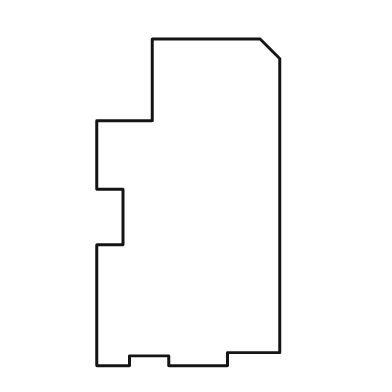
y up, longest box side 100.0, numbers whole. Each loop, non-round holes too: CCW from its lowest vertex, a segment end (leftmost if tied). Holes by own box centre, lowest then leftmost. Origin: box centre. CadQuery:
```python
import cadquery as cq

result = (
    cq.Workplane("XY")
    .moveTo(-28.0, -50.0)
    .lineTo(-18.0, -50.0)
    .lineTo(-18.0, -47.0)
    .lineTo(-6.0, -47.0)
    .lineTo(-6.0, -50.0)
    .lineTo(12.0, -50.0)
    .lineTo(12.0, -46.0)
    .lineTo(28.0, -46.0)
    .lineTo(28.0, 44.0)
    .lineTo(22.0, 50.0)
    .lineTo(-11.0, 50.0)
    .lineTo(-11.0, 25.0)
    .lineTo(-28.0, 25.0)
    .lineTo(-28.0, 4.0)
    .lineTo(-20.0, 4.0)
    .lineTo(-20.0, -13.0)
    .lineTo(-28.0, -13.0)
    .close()
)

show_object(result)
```